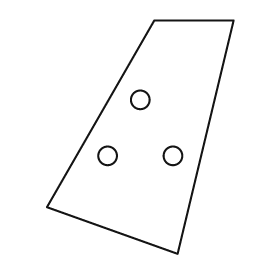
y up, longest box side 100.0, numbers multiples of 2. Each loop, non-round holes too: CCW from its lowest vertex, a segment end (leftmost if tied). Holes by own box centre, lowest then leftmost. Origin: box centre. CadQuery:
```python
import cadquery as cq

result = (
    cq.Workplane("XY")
    .moveTo(16.0, -50.0)
    .lineTo(40.0, 50.0)
    .lineTo(6.0, 50.0)
    .lineTo(-40.0, -30.0)
    .close()
    .moveTo(-14.0, -8.0)
    .circle(4.0)
    .moveTo(14.0, -8.0)
    .circle(4.0)
    .moveTo(0.0, 16.0)
    .circle(4.0)
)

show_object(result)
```